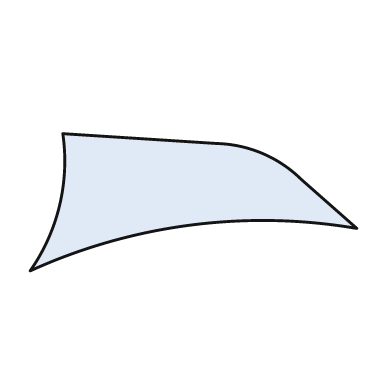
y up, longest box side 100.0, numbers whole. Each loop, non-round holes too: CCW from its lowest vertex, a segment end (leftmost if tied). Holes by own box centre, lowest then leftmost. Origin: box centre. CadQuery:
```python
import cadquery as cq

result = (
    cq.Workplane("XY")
    .moveTo(-50.0, -21.0)
    .threePointArc((-1.0, -7.0), (50.0, -8.0))
    .lineTo(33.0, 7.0)
    .threePointArc((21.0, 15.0), (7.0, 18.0))
    .lineTo(-40.0, 21.0)
    .threePointArc((-41.0, -1.0), (-50.0, -21.0))
    .close()
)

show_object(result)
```